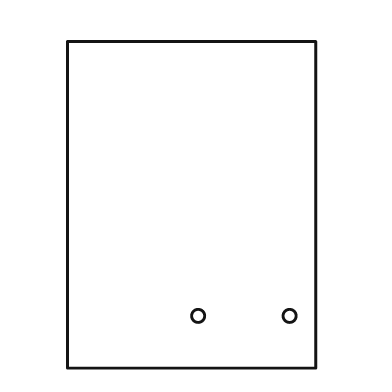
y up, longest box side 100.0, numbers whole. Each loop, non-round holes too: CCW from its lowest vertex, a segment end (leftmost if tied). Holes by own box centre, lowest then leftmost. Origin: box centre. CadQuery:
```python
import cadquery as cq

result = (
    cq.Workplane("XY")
    .moveTo(-38.0, -50.0)
    .lineTo(38.0, -50.0)
    .lineTo(38.0, 50.0)
    .lineTo(-38.0, 50.0)
    .close()
    .moveTo(2.0, -34.0)
    .circle(2.0)
    .moveTo(30.0, -34.0)
    .circle(2.0)
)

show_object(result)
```